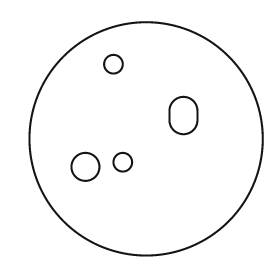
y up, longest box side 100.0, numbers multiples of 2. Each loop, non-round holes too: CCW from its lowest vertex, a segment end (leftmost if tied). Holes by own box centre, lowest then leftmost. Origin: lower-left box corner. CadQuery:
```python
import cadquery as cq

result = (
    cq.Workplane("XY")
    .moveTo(50.0, 50.0)
    .circle(50.0)
    .moveTo(24.0, 38.0)
    .circle(6.0)
    .moveTo(40.0, 40.0)
    .circle(4.0)
    .moveTo(60.0, 58.0)
    .threePointArc((66.0, 52.0), (72.0, 58.0))
    .lineTo(72.0, 62.0)
    .threePointArc((66.0, 68.0), (60.0, 62.0))
    .close()
    .moveTo(36.0, 82.0)
    .circle(4.0)
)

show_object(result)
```